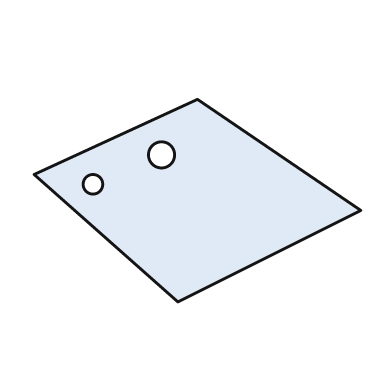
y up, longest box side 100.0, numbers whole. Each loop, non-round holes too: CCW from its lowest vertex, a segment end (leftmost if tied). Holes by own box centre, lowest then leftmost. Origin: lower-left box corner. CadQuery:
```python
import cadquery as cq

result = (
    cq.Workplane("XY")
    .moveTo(44.0, 0.0)
    .lineTo(100.0, 28.0)
    .lineTo(50.0, 62.0)
    .lineTo(0.0, 39.0)
    .close()
    .moveTo(18.0, 36.0)
    .circle(3.0)
    .moveTo(39.0, 45.0)
    .circle(4.0)
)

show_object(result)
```